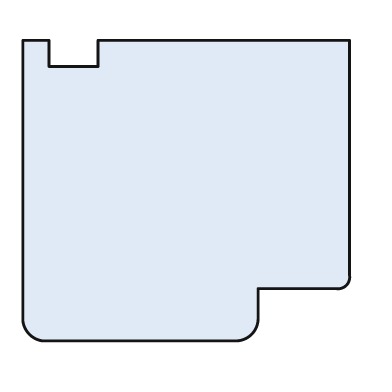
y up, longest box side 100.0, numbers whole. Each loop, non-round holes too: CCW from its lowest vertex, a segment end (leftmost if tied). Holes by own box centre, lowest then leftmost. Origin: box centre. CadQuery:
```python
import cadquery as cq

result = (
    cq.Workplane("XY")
    .moveTo(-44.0, -46.0)
    .lineTo(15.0, -46.0)
    .threePointArc((20.0, -44.0), (22.0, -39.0))
    .lineTo(22.0, -30.0)
    .lineTo(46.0, -30.0)
    .threePointArc((49.0, -29.0), (50.0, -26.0))
    .lineTo(50.0, 46.0)
    .lineTo(-27.0, 46.0)
    .lineTo(-27.0, 38.0)
    .lineTo(-42.0, 38.0)
    .lineTo(-42.0, 46.0)
    .lineTo(-50.0, 46.0)
    .lineTo(-50.0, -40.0)
    .threePointArc((-48.0, -44.0), (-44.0, -46.0))
    .close()
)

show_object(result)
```